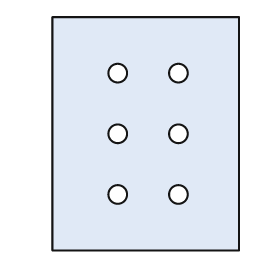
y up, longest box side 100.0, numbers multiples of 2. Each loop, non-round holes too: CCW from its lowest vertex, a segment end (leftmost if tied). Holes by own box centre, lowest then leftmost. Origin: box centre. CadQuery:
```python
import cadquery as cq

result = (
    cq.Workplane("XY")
    .moveTo(-40.0, -50.0)
    .lineTo(40.0, -50.0)
    .lineTo(40.0, 50.0)
    .lineTo(-40.0, 50.0)
    .close()
    .moveTo(-12.0, -26.0)
    .circle(4.0)
    .moveTo(14.0, -26.0)
    .circle(4.0)
    .moveTo(-12.0, 0.0)
    .circle(4.0)
    .moveTo(14.0, 0.0)
    .circle(4.0)
    .moveTo(-12.0, 26.0)
    .circle(4.0)
    .moveTo(14.0, 26.0)
    .circle(4.0)
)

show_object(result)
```